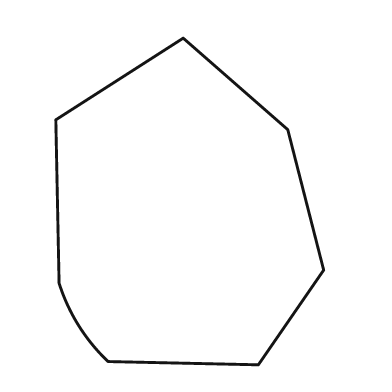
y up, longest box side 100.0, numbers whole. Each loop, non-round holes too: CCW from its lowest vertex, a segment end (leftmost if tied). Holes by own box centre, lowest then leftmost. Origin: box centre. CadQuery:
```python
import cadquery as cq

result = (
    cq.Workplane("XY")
    .moveTo(21.0, -50.0)
    .lineTo(41.0, -21.0)
    .lineTo(30.0, 22.0)
    .lineTo(-2.0, 50.0)
    .lineTo(-41.0, 25.0)
    .lineTo(-40.0, -25.0)
    .threePointArc((-34.0, -38.0), (-25.0, -49.0))
    .close()
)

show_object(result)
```